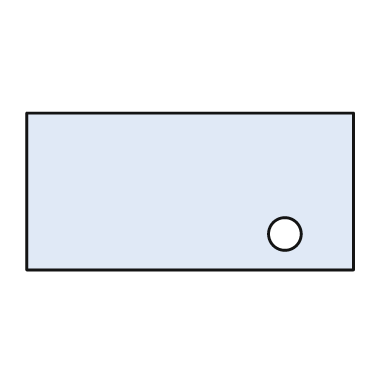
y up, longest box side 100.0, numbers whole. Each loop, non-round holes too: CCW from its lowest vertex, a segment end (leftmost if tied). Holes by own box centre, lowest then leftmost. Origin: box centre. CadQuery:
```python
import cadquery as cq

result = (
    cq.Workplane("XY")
    .moveTo(-50.0, -24.0)
    .lineTo(50.0, -24.0)
    .lineTo(50.0, 24.0)
    .lineTo(-50.0, 24.0)
    .close()
    .moveTo(29.0, -13.0)
    .circle(5.0)
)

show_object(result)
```